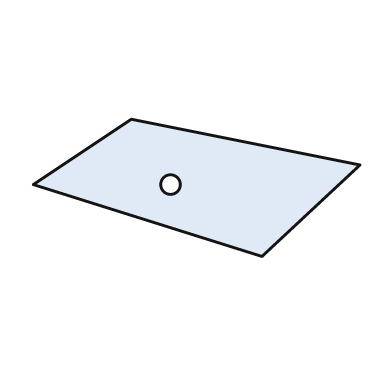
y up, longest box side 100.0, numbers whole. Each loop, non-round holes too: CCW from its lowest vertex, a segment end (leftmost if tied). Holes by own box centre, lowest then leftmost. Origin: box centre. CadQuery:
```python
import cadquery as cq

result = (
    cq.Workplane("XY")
    .moveTo(20.0, -21.0)
    .lineTo(50.0, 7.0)
    .lineTo(-20.0, 21.0)
    .lineTo(-50.0, 1.0)
    .close()
    .moveTo(-8.0, 1.0)
    .circle(3.0)
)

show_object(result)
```